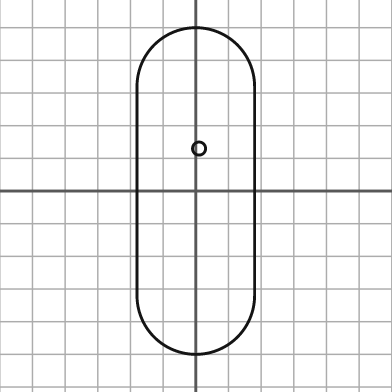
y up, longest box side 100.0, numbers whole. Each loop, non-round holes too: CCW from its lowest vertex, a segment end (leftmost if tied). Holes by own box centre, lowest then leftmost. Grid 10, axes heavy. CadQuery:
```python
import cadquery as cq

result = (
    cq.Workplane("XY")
    .moveTo(-18.0, -32.0)
    .threePointArc((0.0, -50.0), (18.0, -32.0))
    .lineTo(18.0, 32.0)
    .threePointArc((0.0, 50.0), (-18.0, 32.0))
    .close()
    .moveTo(1.0, 13.0)
    .circle(2.0)
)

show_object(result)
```